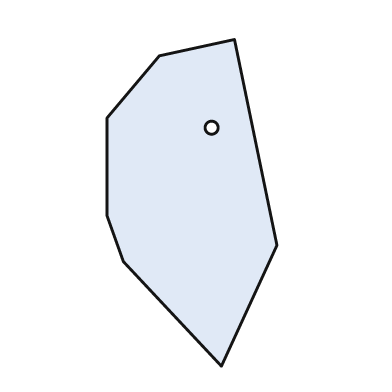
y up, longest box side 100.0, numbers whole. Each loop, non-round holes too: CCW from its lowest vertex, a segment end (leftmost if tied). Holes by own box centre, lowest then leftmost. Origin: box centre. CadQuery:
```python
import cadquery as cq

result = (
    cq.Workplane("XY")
    .moveTo(9.0, -50.0)
    .lineTo(26.0, -13.0)
    .lineTo(13.0, 50.0)
    .lineTo(-10.0, 45.0)
    .lineTo(-26.0, 26.0)
    .lineTo(-26.0, -4.0)
    .lineTo(-21.0, -18.0)
    .close()
    .moveTo(6.0, 23.0)
    .circle(2.0)
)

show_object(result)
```